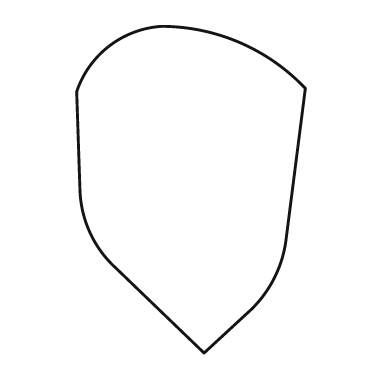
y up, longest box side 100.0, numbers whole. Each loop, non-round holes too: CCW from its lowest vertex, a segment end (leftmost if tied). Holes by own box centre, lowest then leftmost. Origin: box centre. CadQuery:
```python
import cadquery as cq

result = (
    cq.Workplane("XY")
    .moveTo(4.0, -50.0)
    .lineTo(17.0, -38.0)
    .threePointArc((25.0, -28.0), (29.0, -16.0))
    .lineTo(35.0, 31.0)
    .threePointArc((15.0, 45.0), (-9.0, 50.0))
    .threePointArc((-25.0, 44.0), (-35.0, 30.0))
    .lineTo(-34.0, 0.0)
    .threePointArc((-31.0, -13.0), (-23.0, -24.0))
    .close()
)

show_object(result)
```